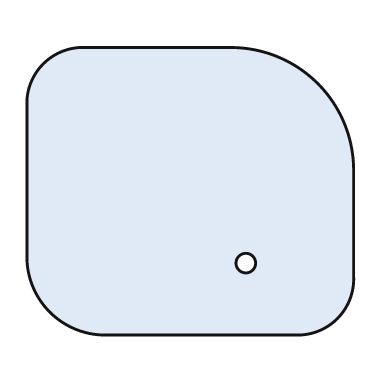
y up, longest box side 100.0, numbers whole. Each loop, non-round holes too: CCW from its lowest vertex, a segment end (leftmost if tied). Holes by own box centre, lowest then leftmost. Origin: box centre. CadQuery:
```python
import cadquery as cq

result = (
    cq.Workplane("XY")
    .moveTo(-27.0, -44.0)
    .lineTo(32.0, -44.0)
    .threePointArc((45.0, -39.0), (50.0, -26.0))
    .lineTo(50.0, 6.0)
    .threePointArc((39.0, 33.0), (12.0, 44.0))
    .lineTo(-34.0, 44.0)
    .threePointArc((-45.0, 39.0), (-50.0, 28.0))
    .lineTo(-50.0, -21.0)
    .threePointArc((-43.0, -37.0), (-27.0, -44.0))
    .close()
    .moveTo(17.0, -22.0)
    .circle(3.0)
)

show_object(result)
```